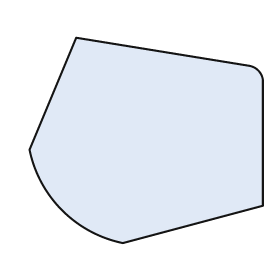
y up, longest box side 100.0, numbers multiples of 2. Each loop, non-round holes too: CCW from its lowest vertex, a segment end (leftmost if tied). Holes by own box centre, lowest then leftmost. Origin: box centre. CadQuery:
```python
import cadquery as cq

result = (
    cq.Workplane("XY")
    .moveTo(-10.0, -44.0)
    .lineTo(50.0, -28.0)
    .lineTo(50.0, 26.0)
    .threePointArc((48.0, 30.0), (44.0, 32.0))
    .lineTo(-30.0, 44.0)
    .lineTo(-50.0, -4.0)
    .threePointArc((-36.0, -30.0), (-10.0, -44.0))
    .close()
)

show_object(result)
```